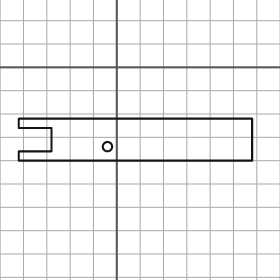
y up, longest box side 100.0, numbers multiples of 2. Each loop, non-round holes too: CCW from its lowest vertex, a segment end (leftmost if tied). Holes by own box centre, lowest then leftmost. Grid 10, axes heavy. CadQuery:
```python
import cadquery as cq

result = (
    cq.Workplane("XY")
    .moveTo(-42.0, -40.0)
    .lineTo(58.0, -40.0)
    .lineTo(58.0, -22.0)
    .lineTo(-42.0, -22.0)
    .lineTo(-42.0, -26.0)
    .lineTo(-28.0, -26.0)
    .lineTo(-28.0, -36.0)
    .lineTo(-42.0, -36.0)
    .close()
    .moveTo(-4.0, -34.0)
    .circle(2.0)
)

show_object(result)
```